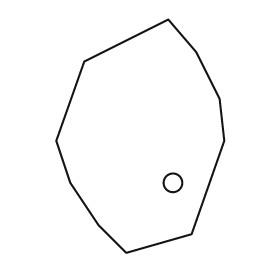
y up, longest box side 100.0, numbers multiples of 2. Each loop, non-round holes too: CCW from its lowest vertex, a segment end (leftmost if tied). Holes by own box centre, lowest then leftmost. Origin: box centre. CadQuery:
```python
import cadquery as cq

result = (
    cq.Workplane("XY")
    .moveTo(-6.0, -50.0)
    .lineTo(22.0, -42.0)
    .lineTo(36.0, -2.0)
    .lineTo(34.0, 16.0)
    .lineTo(24.0, 36.0)
    .lineTo(12.0, 50.0)
    .lineTo(-24.0, 32.0)
    .lineTo(-36.0, -2.0)
    .lineTo(-30.0, -20.0)
    .lineTo(-18.0, -38.0)
    .close()
    .moveTo(14.0, -20.0)
    .circle(4.0)
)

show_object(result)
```